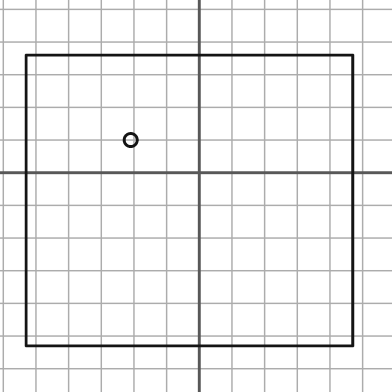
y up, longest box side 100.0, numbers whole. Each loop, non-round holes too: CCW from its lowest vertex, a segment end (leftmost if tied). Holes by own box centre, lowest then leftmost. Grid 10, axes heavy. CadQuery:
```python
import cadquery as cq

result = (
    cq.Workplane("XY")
    .moveTo(-53.0, -53.0)
    .lineTo(47.0, -53.0)
    .lineTo(47.0, 36.0)
    .lineTo(-53.0, 36.0)
    .close()
    .moveTo(-21.0, 10.0)
    .circle(2.0)
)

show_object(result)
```